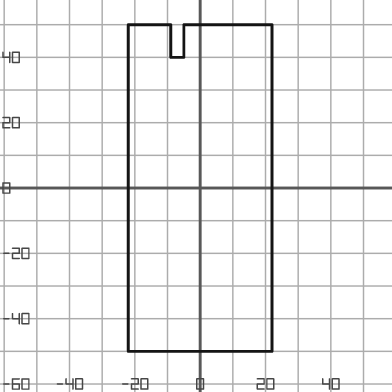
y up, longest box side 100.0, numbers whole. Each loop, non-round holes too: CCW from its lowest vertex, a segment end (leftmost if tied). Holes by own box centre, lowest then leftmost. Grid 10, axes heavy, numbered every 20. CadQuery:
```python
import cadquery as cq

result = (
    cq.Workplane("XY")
    .moveTo(-22.0, -50.0)
    .lineTo(22.0, -50.0)
    .lineTo(22.0, 50.0)
    .lineTo(-5.0, 50.0)
    .lineTo(-5.0, 40.0)
    .lineTo(-9.0, 40.0)
    .lineTo(-9.0, 50.0)
    .lineTo(-22.0, 50.0)
    .close()
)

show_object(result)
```